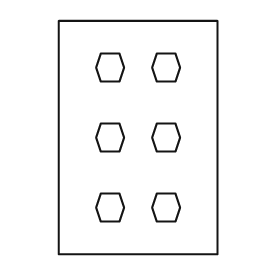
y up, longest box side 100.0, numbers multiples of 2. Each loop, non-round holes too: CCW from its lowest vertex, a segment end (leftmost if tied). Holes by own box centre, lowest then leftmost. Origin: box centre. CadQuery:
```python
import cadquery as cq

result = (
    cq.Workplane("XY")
    .moveTo(-34.0, -50.0)
    .lineTo(34.0, -50.0)
    .lineTo(34.0, 50.0)
    .lineTo(-34.0, 50.0)
    .close()
    .moveTo(-16.0, -36.0)
    .lineTo(-8.0, -36.0)
    .lineTo(-6.0, -30.0)
    .lineTo(-8.0, -24.0)
    .lineTo(-16.0, -24.0)
    .lineTo(-18.0, -30.0)
    .close()
    .moveTo(8.0, -36.0)
    .lineTo(16.0, -36.0)
    .lineTo(18.0, -30.0)
    .lineTo(16.0, -24.0)
    .lineTo(8.0, -24.0)
    .lineTo(6.0, -30.0)
    .close()
    .moveTo(-16.0, -6.0)
    .lineTo(-8.0, -6.0)
    .lineTo(-6.0, 0.0)
    .lineTo(-8.0, 6.0)
    .lineTo(-16.0, 6.0)
    .lineTo(-18.0, 0.0)
    .close()
    .moveTo(8.0, -6.0)
    .lineTo(16.0, -6.0)
    .lineTo(18.0, 0.0)
    .lineTo(16.0, 6.0)
    .lineTo(8.0, 6.0)
    .lineTo(6.0, 0.0)
    .close()
    .moveTo(-16.0, 24.0)
    .lineTo(-8.0, 24.0)
    .lineTo(-6.0, 30.0)
    .lineTo(-8.0, 36.0)
    .lineTo(-16.0, 36.0)
    .lineTo(-18.0, 30.0)
    .close()
    .moveTo(8.0, 24.0)
    .lineTo(16.0, 24.0)
    .lineTo(18.0, 30.0)
    .lineTo(16.0, 36.0)
    .lineTo(8.0, 36.0)
    .lineTo(6.0, 30.0)
    .close()
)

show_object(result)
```